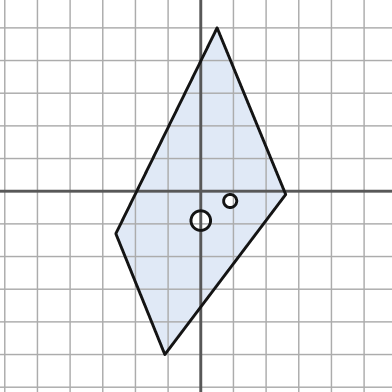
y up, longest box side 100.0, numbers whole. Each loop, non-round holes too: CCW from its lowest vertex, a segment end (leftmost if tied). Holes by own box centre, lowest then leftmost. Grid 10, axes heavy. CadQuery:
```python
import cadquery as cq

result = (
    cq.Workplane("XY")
    .moveTo(-11.0, -50.0)
    .lineTo(26.0, -1.0)
    .lineTo(5.0, 50.0)
    .lineTo(-26.0, -13.0)
    .close()
    .moveTo(0.0, -9.0)
    .circle(3.0)
    .moveTo(9.0, -3.0)
    .circle(2.0)
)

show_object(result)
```